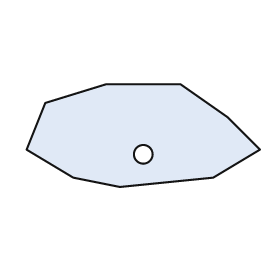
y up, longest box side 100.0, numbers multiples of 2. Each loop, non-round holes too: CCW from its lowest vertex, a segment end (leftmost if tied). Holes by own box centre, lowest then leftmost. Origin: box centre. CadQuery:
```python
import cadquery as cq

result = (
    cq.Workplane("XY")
    .moveTo(-10.0, -22.0)
    .lineTo(30.0, -18.0)
    .lineTo(50.0, -6.0)
    .lineTo(36.0, 8.0)
    .lineTo(16.0, 22.0)
    .lineTo(-16.0, 22.0)
    .lineTo(-42.0, 14.0)
    .lineTo(-50.0, -6.0)
    .lineTo(-30.0, -18.0)
    .close()
    .moveTo(0.0, -8.0)
    .circle(4.0)
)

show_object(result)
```